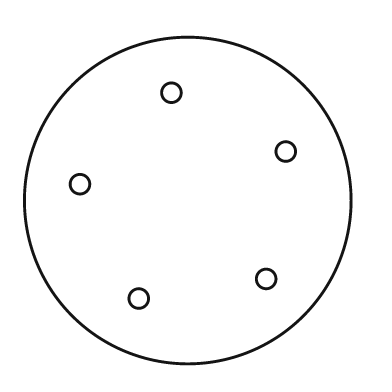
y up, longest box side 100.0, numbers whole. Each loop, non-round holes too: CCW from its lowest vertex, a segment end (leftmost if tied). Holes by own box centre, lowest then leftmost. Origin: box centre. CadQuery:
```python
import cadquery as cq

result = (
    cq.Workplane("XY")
    .moveTo(0.0, 0.0)
    .circle(50.0)
    .moveTo(-15.0, -30.0)
    .circle(3.0)
    .moveTo(24.0, -24.0)
    .circle(3.0)
    .moveTo(-33.0, 5.0)
    .circle(3.0)
    .moveTo(30.0, 15.0)
    .circle(3.0)
    .moveTo(-5.0, 33.0)
    .circle(3.0)
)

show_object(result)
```